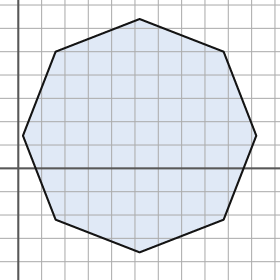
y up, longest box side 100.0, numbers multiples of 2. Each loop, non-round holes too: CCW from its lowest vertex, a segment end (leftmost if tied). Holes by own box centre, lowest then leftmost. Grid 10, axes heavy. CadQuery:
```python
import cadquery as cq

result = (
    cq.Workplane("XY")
    .moveTo(52.0, -36.0)
    .lineTo(88.0, -22.0)
    .lineTo(102.0, 14.0)
    .lineTo(88.0, 50.0)
    .lineTo(52.0, 64.0)
    .lineTo(16.0, 50.0)
    .lineTo(2.0, 14.0)
    .lineTo(16.0, -22.0)
    .close()
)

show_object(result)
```